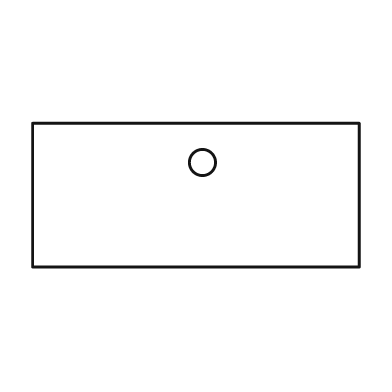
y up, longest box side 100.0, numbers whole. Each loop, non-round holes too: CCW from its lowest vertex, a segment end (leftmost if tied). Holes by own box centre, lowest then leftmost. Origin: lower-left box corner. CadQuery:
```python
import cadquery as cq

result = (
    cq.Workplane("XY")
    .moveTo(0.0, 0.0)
    .lineTo(100.0, 0.0)
    .lineTo(100.0, 44.0)
    .lineTo(0.0, 44.0)
    .close()
    .moveTo(52.0, 32.0)
    .circle(4.0)
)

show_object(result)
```